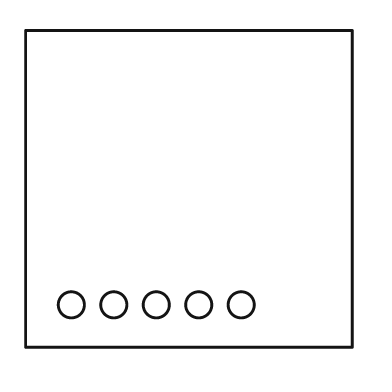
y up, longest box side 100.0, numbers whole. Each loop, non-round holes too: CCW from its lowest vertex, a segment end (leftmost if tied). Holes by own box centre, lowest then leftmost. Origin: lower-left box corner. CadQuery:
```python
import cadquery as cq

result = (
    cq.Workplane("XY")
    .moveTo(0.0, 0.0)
    .lineTo(100.0, 0.0)
    .lineTo(100.0, 97.0)
    .lineTo(0.0, 97.0)
    .close()
    .moveTo(14.0, 13.0)
    .circle(4.0)
    .moveTo(27.0, 13.0)
    .circle(4.0)
    .moveTo(40.0, 13.0)
    .circle(4.0)
    .moveTo(53.0, 13.0)
    .circle(4.0)
    .moveTo(66.0, 13.0)
    .circle(4.0)
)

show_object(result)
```